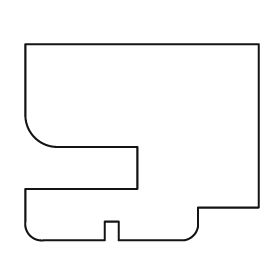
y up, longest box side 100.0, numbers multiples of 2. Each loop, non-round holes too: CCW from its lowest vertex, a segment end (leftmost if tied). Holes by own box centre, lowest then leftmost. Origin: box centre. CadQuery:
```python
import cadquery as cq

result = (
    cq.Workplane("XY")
    .moveTo(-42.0, -42.0)
    .lineTo(-16.0, -42.0)
    .lineTo(-16.0, -34.0)
    .lineTo(-10.0, -34.0)
    .lineTo(-10.0, -42.0)
    .lineTo(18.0, -42.0)
    .threePointArc((22.0, -40.0), (24.0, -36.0))
    .lineTo(24.0, -28.0)
    .lineTo(50.0, -28.0)
    .lineTo(50.0, 42.0)
    .lineTo(-50.0, 42.0)
    .lineTo(-50.0, 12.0)
    .threePointArc((-46.0, 2.0), (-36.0, -2.0))
    .lineTo(-2.0, -2.0)
    .lineTo(-2.0, -20.0)
    .lineTo(-50.0, -20.0)
    .lineTo(-50.0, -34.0)
    .threePointArc((-48.0, -40.0), (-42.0, -42.0))
    .close()
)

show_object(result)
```